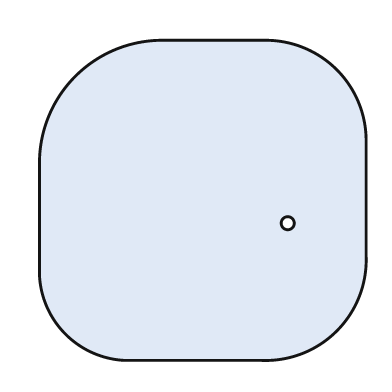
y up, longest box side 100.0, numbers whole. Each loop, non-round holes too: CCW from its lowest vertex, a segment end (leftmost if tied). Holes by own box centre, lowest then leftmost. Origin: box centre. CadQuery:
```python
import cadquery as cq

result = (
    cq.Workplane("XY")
    .moveTo(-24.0, -49.0)
    .lineTo(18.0, -49.0)
    .threePointArc((41.0, -40.0), (50.0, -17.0))
    .lineTo(50.0, 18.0)
    .threePointArc((41.0, 40.0), (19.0, 49.0))
    .lineTo(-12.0, 49.0)
    .threePointArc((-39.0, 38.0), (-50.0, 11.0))
    .lineTo(-50.0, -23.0)
    .threePointArc((-42.0, -41.0), (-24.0, -49.0))
    .close()
    .moveTo(26.0, -7.0)
    .circle(2.0)
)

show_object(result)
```